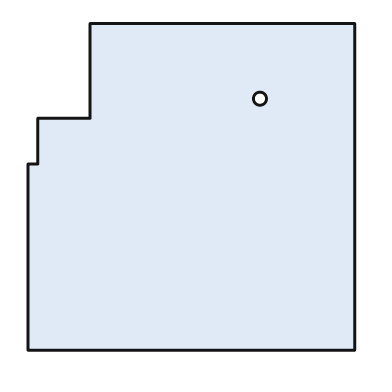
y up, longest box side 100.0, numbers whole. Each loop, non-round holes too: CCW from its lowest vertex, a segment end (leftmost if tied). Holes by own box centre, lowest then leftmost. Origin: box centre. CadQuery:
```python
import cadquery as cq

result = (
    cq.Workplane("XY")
    .moveTo(-50.0, -50.0)
    .lineTo(50.0, -50.0)
    .lineTo(50.0, 50.0)
    .lineTo(-31.0, 50.0)
    .lineTo(-31.0, 21.0)
    .lineTo(-47.0, 21.0)
    .lineTo(-47.0, 7.0)
    .lineTo(-50.0, 7.0)
    .close()
    .moveTo(21.0, 27.0)
    .circle(2.0)
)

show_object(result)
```